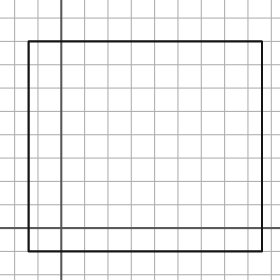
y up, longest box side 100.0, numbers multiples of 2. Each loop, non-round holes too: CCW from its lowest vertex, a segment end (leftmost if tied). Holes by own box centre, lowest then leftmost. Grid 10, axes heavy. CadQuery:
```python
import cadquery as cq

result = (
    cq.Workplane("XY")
    .moveTo(-14.0, -10.0)
    .lineTo(86.0, -10.0)
    .lineTo(86.0, 80.0)
    .lineTo(-14.0, 80.0)
    .close()
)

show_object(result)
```